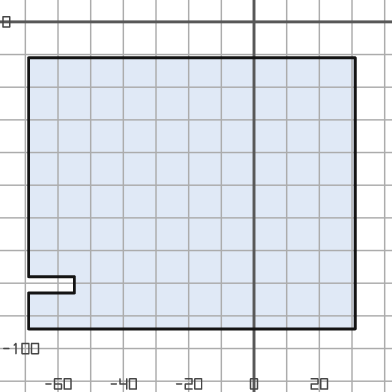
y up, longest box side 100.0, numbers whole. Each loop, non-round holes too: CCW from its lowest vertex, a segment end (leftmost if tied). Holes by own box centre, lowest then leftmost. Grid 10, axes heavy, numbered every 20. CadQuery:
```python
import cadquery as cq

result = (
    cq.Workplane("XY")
    .moveTo(-69.0, -94.0)
    .lineTo(31.0, -94.0)
    .lineTo(31.0, -11.0)
    .lineTo(-69.0, -11.0)
    .lineTo(-69.0, -78.0)
    .lineTo(-55.0, -78.0)
    .lineTo(-55.0, -83.0)
    .lineTo(-69.0, -83.0)
    .close()
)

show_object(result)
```